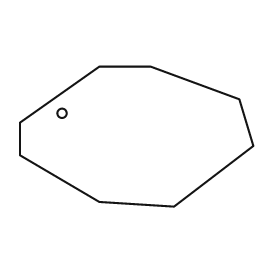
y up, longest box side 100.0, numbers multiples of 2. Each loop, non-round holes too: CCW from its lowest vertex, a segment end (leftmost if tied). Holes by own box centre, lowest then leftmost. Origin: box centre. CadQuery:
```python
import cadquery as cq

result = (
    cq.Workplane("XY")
    .moveTo(16.0, -30.0)
    .lineTo(50.0, -4.0)
    .lineTo(44.0, 16.0)
    .lineTo(6.0, 30.0)
    .lineTo(-16.0, 30.0)
    .lineTo(-50.0, 6.0)
    .lineTo(-50.0, -8.0)
    .lineTo(-16.0, -28.0)
    .close()
    .moveTo(-32.0, 10.0)
    .circle(2.0)
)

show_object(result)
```